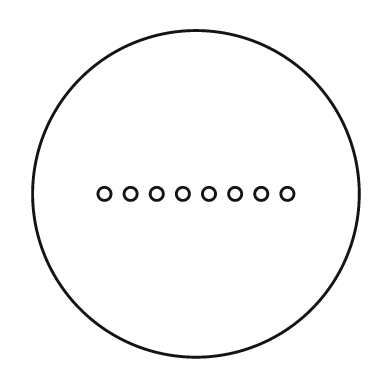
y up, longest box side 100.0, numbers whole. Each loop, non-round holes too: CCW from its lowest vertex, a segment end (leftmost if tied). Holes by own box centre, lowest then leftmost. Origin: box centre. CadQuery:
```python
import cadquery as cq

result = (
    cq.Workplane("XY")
    .moveTo(0.0, 0.0)
    .circle(50.0)
    .moveTo(-28.0, 0.0)
    .circle(2.0)
    .moveTo(-20.0, 0.0)
    .circle(2.0)
    .moveTo(-12.0, 0.0)
    .circle(2.0)
    .moveTo(-4.0, 0.0)
    .circle(2.0)
    .moveTo(4.0, 0.0)
    .circle(2.0)
    .moveTo(12.0, 0.0)
    .circle(2.0)
    .moveTo(20.0, 0.0)
    .circle(2.0)
    .moveTo(28.0, 0.0)
    .circle(2.0)
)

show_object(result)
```